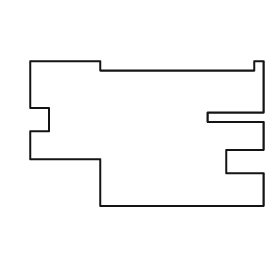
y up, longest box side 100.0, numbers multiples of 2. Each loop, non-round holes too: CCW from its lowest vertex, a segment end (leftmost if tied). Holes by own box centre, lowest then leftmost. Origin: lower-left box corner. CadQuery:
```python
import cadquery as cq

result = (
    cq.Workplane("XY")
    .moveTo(30.0, 0.0)
    .lineTo(100.0, 0.0)
    .lineTo(100.0, 14.0)
    .lineTo(84.0, 14.0)
    .lineTo(84.0, 24.0)
    .lineTo(100.0, 24.0)
    .lineTo(100.0, 36.0)
    .lineTo(76.0, 36.0)
    .lineTo(76.0, 40.0)
    .lineTo(100.0, 40.0)
    .lineTo(100.0, 62.0)
    .lineTo(96.0, 62.0)
    .lineTo(96.0, 58.0)
    .lineTo(30.0, 58.0)
    .lineTo(30.0, 62.0)
    .lineTo(0.0, 62.0)
    .lineTo(0.0, 42.0)
    .lineTo(8.0, 42.0)
    .lineTo(8.0, 32.0)
    .lineTo(0.0, 32.0)
    .lineTo(0.0, 20.0)
    .lineTo(30.0, 20.0)
    .close()
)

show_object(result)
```